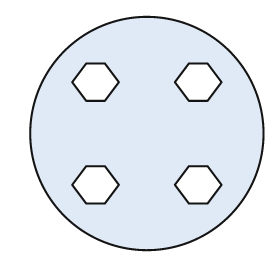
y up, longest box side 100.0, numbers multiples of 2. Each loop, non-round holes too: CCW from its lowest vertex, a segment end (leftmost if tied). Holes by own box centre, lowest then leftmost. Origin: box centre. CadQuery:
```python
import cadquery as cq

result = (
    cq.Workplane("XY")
    .moveTo(0.0, 0.0)
    .circle(50.0)
    .moveTo(-26.0, -30.0)
    .lineTo(-18.0, -30.0)
    .lineTo(-12.0, -22.0)
    .lineTo(-18.0, -14.0)
    .lineTo(-26.0, -14.0)
    .lineTo(-32.0, -22.0)
    .close()
    .moveTo(18.0, -30.0)
    .lineTo(26.0, -30.0)
    .lineTo(32.0, -22.0)
    .lineTo(26.0, -14.0)
    .lineTo(18.0, -14.0)
    .lineTo(12.0, -22.0)
    .close()
    .moveTo(-26.0, 14.0)
    .lineTo(-18.0, 14.0)
    .lineTo(-12.0, 22.0)
    .lineTo(-18.0, 30.0)
    .lineTo(-26.0, 30.0)
    .lineTo(-32.0, 22.0)
    .close()
    .moveTo(18.0, 14.0)
    .lineTo(26.0, 14.0)
    .lineTo(32.0, 22.0)
    .lineTo(26.0, 30.0)
    .lineTo(18.0, 30.0)
    .lineTo(12.0, 22.0)
    .close()
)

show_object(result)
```